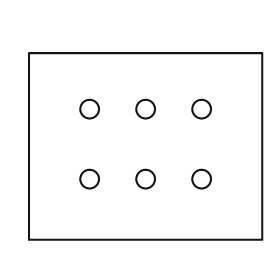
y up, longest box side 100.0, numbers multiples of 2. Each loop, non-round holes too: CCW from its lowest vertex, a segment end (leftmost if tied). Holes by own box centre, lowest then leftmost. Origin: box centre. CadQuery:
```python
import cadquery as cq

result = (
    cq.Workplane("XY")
    .moveTo(-50.0, -40.0)
    .lineTo(50.0, -40.0)
    .lineTo(50.0, 40.0)
    .lineTo(-50.0, 40.0)
    .close()
    .moveTo(-24.0, -14.0)
    .circle(4.0)
    .moveTo(0.0, -14.0)
    .circle(4.0)
    .moveTo(24.0, -14.0)
    .circle(4.0)
    .moveTo(-24.0, 16.0)
    .circle(4.0)
    .moveTo(0.0, 16.0)
    .circle(4.0)
    .moveTo(24.0, 16.0)
    .circle(4.0)
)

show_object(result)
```